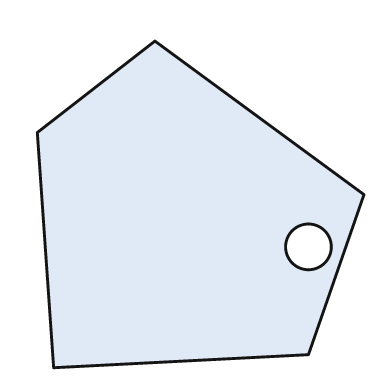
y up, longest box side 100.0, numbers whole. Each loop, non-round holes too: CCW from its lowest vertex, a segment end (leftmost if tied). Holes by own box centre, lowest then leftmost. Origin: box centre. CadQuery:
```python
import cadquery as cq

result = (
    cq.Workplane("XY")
    .moveTo(-45.0, -50.0)
    .lineTo(33.0, -46.0)
    .lineTo(50.0, 3.0)
    .lineTo(-14.0, 50.0)
    .lineTo(-50.0, 22.0)
    .close()
    .moveTo(33.0, -13.0)
    .circle(7.0)
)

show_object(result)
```